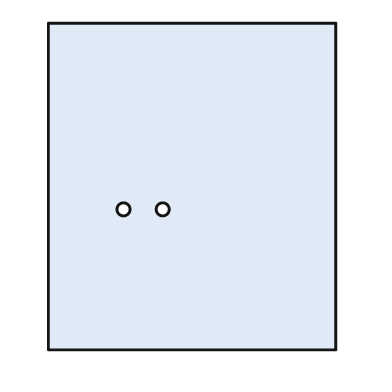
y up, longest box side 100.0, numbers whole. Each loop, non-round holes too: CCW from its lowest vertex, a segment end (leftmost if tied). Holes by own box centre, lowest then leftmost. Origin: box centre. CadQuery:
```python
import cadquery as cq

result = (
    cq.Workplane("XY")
    .moveTo(-44.0, -50.0)
    .lineTo(44.0, -50.0)
    .lineTo(44.0, 50.0)
    .lineTo(-44.0, 50.0)
    .close()
    .moveTo(-21.0, -7.0)
    .circle(2.0)
    .moveTo(-9.0, -7.0)
    .circle(2.0)
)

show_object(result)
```